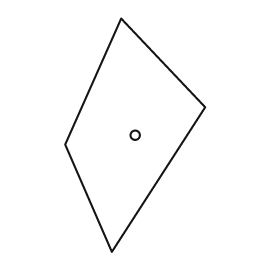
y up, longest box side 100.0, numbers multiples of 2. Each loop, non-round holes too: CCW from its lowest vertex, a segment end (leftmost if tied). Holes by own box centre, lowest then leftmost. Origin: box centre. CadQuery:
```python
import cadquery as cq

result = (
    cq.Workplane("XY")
    .moveTo(-10.0, -50.0)
    .lineTo(30.0, 12.0)
    .lineTo(-6.0, 50.0)
    .lineTo(-30.0, -4.0)
    .close()
    .moveTo(0.0, 0.0)
    .circle(2.0)
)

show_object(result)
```